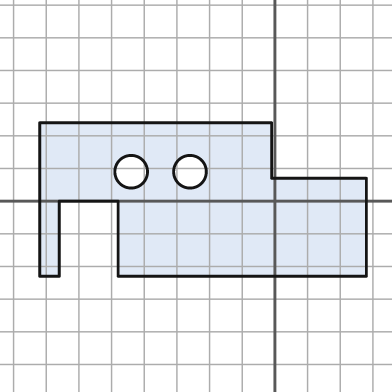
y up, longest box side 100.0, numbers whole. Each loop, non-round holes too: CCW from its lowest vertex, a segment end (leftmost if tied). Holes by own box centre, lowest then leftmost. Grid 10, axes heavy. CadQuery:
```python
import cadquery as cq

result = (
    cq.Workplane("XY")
    .moveTo(-72.0, -23.0)
    .lineTo(-66.0, -23.0)
    .lineTo(-66.0, 0.0)
    .lineTo(-48.0, 0.0)
    .lineTo(-48.0, -23.0)
    .lineTo(28.0, -23.0)
    .lineTo(28.0, 7.0)
    .lineTo(-1.0, 7.0)
    .lineTo(-1.0, 24.0)
    .lineTo(-72.0, 24.0)
    .close()
    .moveTo(-44.0, 9.0)
    .circle(5.0)
    .moveTo(-26.0, 9.0)
    .circle(5.0)
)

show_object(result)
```